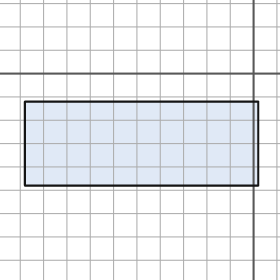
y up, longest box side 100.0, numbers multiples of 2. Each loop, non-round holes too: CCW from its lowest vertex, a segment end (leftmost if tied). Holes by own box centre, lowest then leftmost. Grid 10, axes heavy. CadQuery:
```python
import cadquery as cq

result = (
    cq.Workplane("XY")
    .moveTo(-98.0, -48.0)
    .lineTo(2.0, -48.0)
    .lineTo(2.0, -12.0)
    .lineTo(-98.0, -12.0)
    .close()
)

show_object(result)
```